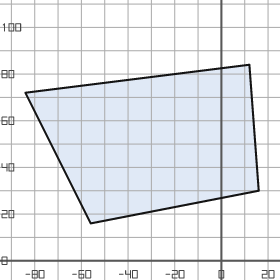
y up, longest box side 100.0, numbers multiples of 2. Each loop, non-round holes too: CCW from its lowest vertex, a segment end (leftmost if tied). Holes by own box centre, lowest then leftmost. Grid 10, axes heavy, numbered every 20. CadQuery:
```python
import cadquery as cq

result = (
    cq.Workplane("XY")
    .moveTo(-56.0, 16.0)
    .lineTo(16.0, 30.0)
    .lineTo(12.0, 84.0)
    .lineTo(-84.0, 72.0)
    .close()
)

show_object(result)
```